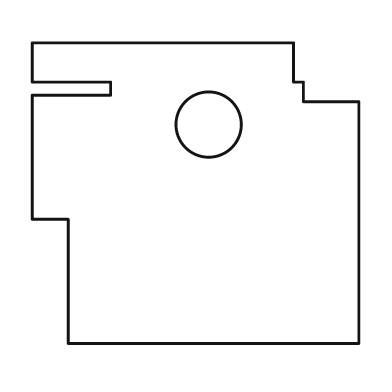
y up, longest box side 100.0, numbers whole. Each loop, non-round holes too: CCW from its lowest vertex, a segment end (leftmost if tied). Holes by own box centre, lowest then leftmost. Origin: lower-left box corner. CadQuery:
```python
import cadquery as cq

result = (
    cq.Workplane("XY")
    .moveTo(11.0, 0.0)
    .lineTo(100.0, 0.0)
    .lineTo(100.0, 74.0)
    .lineTo(83.0, 74.0)
    .lineTo(83.0, 80.0)
    .lineTo(80.0, 80.0)
    .lineTo(80.0, 92.0)
    .lineTo(0.0, 92.0)
    .lineTo(0.0, 80.0)
    .lineTo(24.0, 80.0)
    .lineTo(24.0, 76.0)
    .lineTo(0.0, 76.0)
    .lineTo(0.0, 38.0)
    .lineTo(11.0, 38.0)
    .close()
    .moveTo(54.0, 67.0)
    .circle(10.0)
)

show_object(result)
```